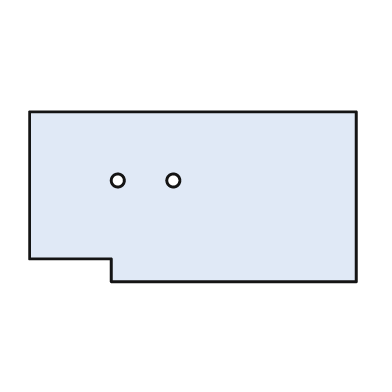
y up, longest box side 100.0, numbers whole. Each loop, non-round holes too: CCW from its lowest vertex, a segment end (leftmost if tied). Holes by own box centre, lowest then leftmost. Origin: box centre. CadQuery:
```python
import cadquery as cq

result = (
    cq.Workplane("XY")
    .moveTo(-25.0, -26.0)
    .lineTo(50.0, -26.0)
    .lineTo(50.0, 26.0)
    .lineTo(-50.0, 26.0)
    .lineTo(-50.0, -19.0)
    .lineTo(-25.0, -19.0)
    .close()
    .moveTo(-23.0, 5.0)
    .circle(2.0)
    .moveTo(-6.0, 5.0)
    .circle(2.0)
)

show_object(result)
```